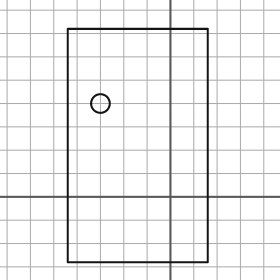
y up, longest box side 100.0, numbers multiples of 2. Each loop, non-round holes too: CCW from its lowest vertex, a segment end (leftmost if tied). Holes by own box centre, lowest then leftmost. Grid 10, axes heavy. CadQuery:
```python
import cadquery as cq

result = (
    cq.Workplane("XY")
    .moveTo(-44.0, -28.0)
    .lineTo(16.0, -28.0)
    .lineTo(16.0, 72.0)
    .lineTo(-44.0, 72.0)
    .close()
    .moveTo(-30.0, 40.0)
    .circle(4.0)
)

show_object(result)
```